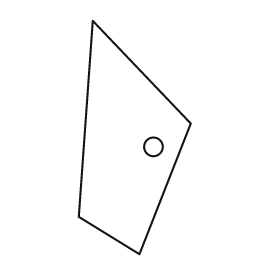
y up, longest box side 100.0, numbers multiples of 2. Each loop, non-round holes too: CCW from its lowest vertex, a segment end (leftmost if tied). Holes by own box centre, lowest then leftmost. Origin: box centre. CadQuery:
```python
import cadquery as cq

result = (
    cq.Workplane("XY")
    .moveTo(2.0, -50.0)
    .lineTo(24.0, 6.0)
    .lineTo(-18.0, 50.0)
    .lineTo(-24.0, -34.0)
    .close()
    .moveTo(8.0, -4.0)
    .circle(4.0)
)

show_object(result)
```